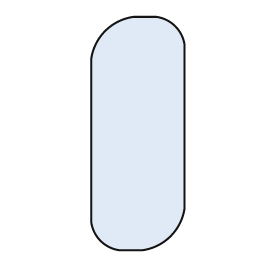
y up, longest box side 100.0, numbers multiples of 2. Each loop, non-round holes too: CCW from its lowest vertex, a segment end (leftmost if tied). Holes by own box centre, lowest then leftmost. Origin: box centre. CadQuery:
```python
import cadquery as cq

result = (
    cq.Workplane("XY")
    .moveTo(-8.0, -50.0)
    .lineTo(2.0, -50.0)
    .threePointArc((14.0, -44.0), (20.0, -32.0))
    .lineTo(20.0, 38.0)
    .threePointArc((16.0, 46.0), (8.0, 50.0))
    .lineTo(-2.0, 50.0)
    .threePointArc((-14.0, 44.0), (-20.0, 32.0))
    .lineTo(-20.0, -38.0)
    .threePointArc((-16.0, -46.0), (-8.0, -50.0))
    .close()
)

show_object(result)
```